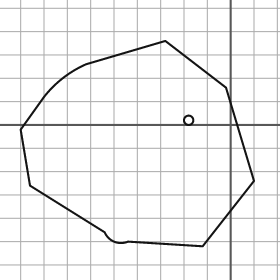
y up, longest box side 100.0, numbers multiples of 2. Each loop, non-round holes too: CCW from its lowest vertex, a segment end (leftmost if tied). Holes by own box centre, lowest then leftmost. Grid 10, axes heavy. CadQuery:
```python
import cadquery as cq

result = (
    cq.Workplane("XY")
    .moveTo(-12.0, -52.0)
    .lineTo(10.0, -24.0)
    .lineTo(-2.0, 16.0)
    .lineTo(-28.0, 36.0)
    .lineTo(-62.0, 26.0)
    .threePointArc((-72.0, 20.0), (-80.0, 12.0))
    .lineTo(-90.0, -2.0)
    .lineTo(-86.0, -26.0)
    .lineTo(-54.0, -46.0)
    .threePointArc((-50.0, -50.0), (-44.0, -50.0))
    .close()
    .moveTo(-18.0, 2.0)
    .circle(2.0)
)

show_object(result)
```